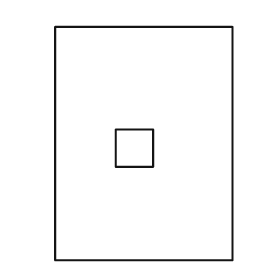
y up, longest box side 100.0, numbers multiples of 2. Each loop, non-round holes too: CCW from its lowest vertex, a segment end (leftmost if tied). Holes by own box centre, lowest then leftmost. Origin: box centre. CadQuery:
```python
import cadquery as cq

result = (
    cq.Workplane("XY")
    .moveTo(-38.0, -50.0)
    .lineTo(38.0, -50.0)
    .lineTo(38.0, 50.0)
    .lineTo(-38.0, 50.0)
    .close()
    .moveTo(-12.0, -10.0)
    .lineTo(4.0, -10.0)
    .lineTo(4.0, 6.0)
    .lineTo(-12.0, 6.0)
    .close()
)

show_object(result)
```